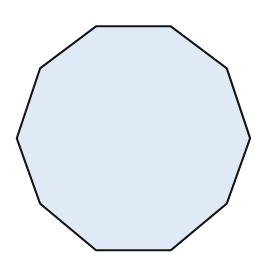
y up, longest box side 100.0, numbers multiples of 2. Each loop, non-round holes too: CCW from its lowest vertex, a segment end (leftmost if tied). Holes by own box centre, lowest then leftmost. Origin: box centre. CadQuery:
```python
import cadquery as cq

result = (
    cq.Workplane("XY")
    .moveTo(-16.0, -48.0)
    .lineTo(16.0, -48.0)
    .lineTo(40.0, -28.0)
    .lineTo(50.0, 0.0)
    .lineTo(40.0, 30.0)
    .lineTo(16.0, 48.0)
    .lineTo(-16.0, 48.0)
    .lineTo(-40.0, 30.0)
    .lineTo(-50.0, 0.0)
    .lineTo(-40.0, -28.0)
    .close()
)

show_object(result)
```